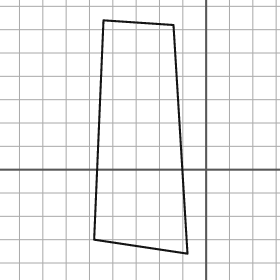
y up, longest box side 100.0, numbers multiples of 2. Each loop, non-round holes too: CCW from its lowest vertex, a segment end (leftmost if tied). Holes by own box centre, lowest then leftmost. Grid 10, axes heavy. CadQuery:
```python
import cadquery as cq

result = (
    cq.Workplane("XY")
    .moveTo(-8.0, -36.0)
    .lineTo(-14.0, 62.0)
    .lineTo(-44.0, 64.0)
    .lineTo(-48.0, -30.0)
    .close()
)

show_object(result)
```